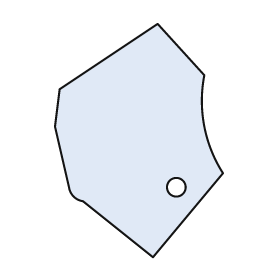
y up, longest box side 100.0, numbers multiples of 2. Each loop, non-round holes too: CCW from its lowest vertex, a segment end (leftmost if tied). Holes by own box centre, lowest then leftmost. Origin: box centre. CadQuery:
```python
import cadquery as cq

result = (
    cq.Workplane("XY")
    .moveTo(6.0, -50.0)
    .lineTo(36.0, -14.0)
    .threePointArc((28.0, 6.0), (28.0, 28.0))
    .lineTo(8.0, 50.0)
    .lineTo(-34.0, 22.0)
    .lineTo(-36.0, 6.0)
    .lineTo(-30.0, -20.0)
    .threePointArc((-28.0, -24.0), (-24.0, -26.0))
    .close()
    .moveTo(16.0, -20.0)
    .circle(4.0)
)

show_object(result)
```